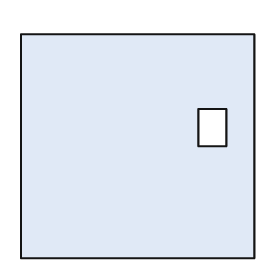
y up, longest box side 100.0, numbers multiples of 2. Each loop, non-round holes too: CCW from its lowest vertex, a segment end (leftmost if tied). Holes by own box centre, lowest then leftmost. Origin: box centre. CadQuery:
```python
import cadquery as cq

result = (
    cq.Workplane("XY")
    .moveTo(-50.0, -48.0)
    .lineTo(50.0, -48.0)
    .lineTo(50.0, 48.0)
    .lineTo(-50.0, 48.0)
    .close()
    .moveTo(26.0, 0.0)
    .lineTo(38.0, 0.0)
    .lineTo(38.0, 16.0)
    .lineTo(26.0, 16.0)
    .close()
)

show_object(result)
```